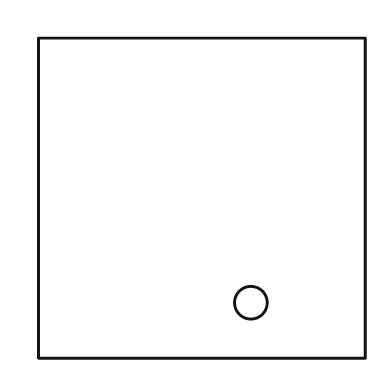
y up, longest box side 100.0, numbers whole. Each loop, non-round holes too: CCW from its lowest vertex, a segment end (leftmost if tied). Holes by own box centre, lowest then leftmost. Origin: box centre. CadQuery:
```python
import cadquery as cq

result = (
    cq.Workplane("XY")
    .moveTo(-50.0, -49.0)
    .lineTo(50.0, -49.0)
    .lineTo(50.0, 49.0)
    .lineTo(-50.0, 49.0)
    .close()
    .moveTo(15.0, -32.0)
    .circle(5.0)
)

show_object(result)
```